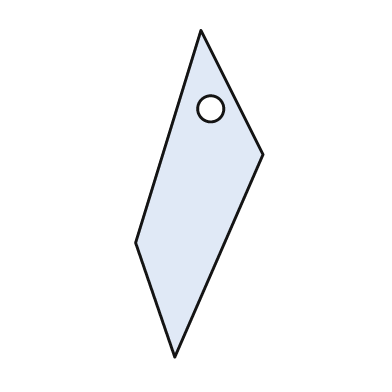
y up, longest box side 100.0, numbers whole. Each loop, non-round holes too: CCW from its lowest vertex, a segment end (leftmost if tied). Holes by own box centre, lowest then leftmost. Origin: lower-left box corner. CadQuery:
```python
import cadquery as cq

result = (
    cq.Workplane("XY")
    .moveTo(12.0, 0.0)
    .lineTo(39.0, 62.0)
    .lineTo(20.0, 100.0)
    .lineTo(0.0, 35.0)
    .close()
    .moveTo(23.0, 76.0)
    .circle(4.0)
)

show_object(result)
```